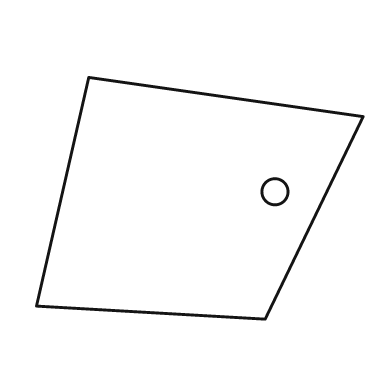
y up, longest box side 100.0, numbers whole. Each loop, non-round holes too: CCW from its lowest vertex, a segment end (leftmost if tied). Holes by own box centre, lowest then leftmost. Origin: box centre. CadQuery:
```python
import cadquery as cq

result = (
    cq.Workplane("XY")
    .moveTo(20.0, -37.0)
    .lineTo(50.0, 25.0)
    .lineTo(-34.0, 37.0)
    .lineTo(-50.0, -33.0)
    .close()
    .moveTo(23.0, 2.0)
    .circle(4.0)
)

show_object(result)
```